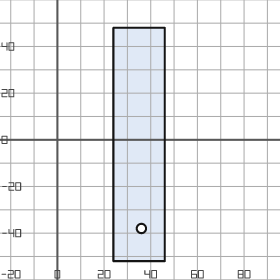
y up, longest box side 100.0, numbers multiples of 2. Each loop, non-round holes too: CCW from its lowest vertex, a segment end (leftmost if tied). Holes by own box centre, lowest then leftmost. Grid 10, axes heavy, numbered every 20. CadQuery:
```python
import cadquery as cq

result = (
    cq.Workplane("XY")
    .moveTo(24.0, -52.0)
    .lineTo(46.0, -52.0)
    .lineTo(46.0, 48.0)
    .lineTo(24.0, 48.0)
    .close()
    .moveTo(36.0, -38.0)
    .circle(2.0)
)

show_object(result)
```